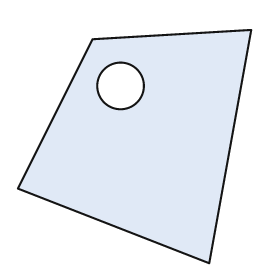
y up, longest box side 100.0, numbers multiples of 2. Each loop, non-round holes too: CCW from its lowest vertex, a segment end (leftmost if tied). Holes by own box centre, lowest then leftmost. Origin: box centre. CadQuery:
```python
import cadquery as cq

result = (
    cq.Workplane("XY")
    .moveTo(32.0, -50.0)
    .lineTo(50.0, 50.0)
    .lineTo(-18.0, 46.0)
    .lineTo(-50.0, -18.0)
    .close()
    .moveTo(-6.0, 26.0)
    .circle(10.0)
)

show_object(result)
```